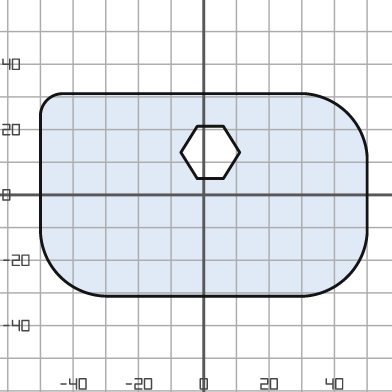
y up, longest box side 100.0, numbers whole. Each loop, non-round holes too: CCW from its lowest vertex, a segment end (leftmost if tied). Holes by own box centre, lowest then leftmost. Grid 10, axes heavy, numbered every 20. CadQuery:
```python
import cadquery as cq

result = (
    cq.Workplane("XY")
    .moveTo(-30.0, -31.0)
    .lineTo(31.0, -31.0)
    .threePointArc((44.0, -25.0), (50.0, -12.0))
    .lineTo(50.0, 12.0)
    .threePointArc((44.0, 25.0), (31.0, 31.0))
    .lineTo(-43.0, 31.0)
    .threePointArc((-48.0, 29.0), (-50.0, 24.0))
    .lineTo(-50.0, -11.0)
    .threePointArc((-44.0, -25.0), (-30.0, -31.0))
    .close()
    .moveTo(-2.0, 5.0)
    .lineTo(6.0, 5.0)
    .lineTo(11.0, 13.0)
    .lineTo(6.0, 21.0)
    .lineTo(-2.0, 21.0)
    .lineTo(-7.0, 13.0)
    .close()
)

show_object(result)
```